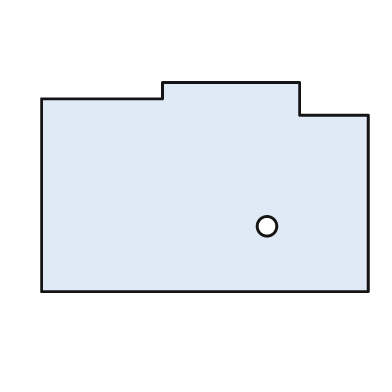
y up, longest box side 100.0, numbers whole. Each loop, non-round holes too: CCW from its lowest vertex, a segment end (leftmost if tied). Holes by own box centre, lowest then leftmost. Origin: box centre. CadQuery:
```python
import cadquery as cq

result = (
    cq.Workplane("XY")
    .moveTo(-50.0, -32.0)
    .lineTo(50.0, -32.0)
    .lineTo(50.0, 22.0)
    .lineTo(29.0, 22.0)
    .lineTo(29.0, 32.0)
    .lineTo(-13.0, 32.0)
    .lineTo(-13.0, 27.0)
    .lineTo(-50.0, 27.0)
    .close()
    .moveTo(19.0, -12.0)
    .circle(3.0)
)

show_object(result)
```